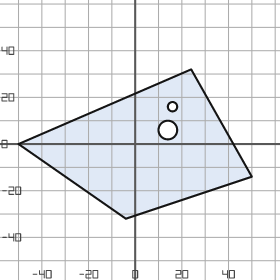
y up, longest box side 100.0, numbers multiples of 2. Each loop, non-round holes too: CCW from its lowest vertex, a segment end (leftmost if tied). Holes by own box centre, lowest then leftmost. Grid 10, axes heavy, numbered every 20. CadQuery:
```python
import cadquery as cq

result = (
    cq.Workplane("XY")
    .moveTo(-4.0, -32.0)
    .lineTo(50.0, -14.0)
    .lineTo(24.0, 32.0)
    .lineTo(-50.0, 0.0)
    .close()
    .moveTo(14.0, 6.0)
    .circle(4.0)
    .moveTo(16.0, 16.0)
    .circle(2.0)
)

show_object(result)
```